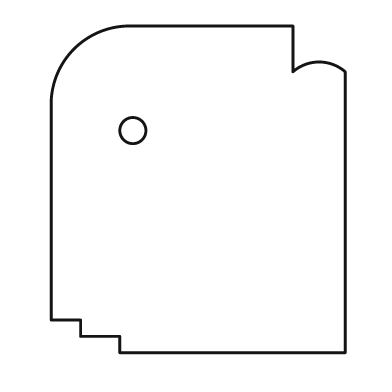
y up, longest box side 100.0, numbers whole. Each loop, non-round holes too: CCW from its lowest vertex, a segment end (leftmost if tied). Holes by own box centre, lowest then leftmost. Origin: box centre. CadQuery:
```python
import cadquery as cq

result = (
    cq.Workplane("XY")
    .moveTo(-24.0, -50.0)
    .lineTo(45.0, -50.0)
    .lineTo(45.0, 36.0)
    .threePointArc((37.0, 39.0), (29.0, 36.0))
    .lineTo(29.0, 50.0)
    .lineTo(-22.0, 50.0)
    .threePointArc((-38.0, 43.0), (-45.0, 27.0))
    .lineTo(-45.0, -40.0)
    .lineTo(-36.0, -40.0)
    .lineTo(-36.0, -45.0)
    .lineTo(-24.0, -45.0)
    .close()
    .moveTo(-20.0, 18.0)
    .circle(4.0)
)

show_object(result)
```